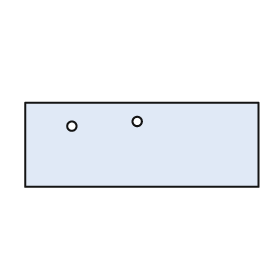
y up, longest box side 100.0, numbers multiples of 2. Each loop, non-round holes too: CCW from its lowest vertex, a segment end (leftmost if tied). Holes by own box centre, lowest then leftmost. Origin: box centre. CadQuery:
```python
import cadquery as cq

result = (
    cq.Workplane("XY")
    .moveTo(-50.0, -18.0)
    .lineTo(50.0, -18.0)
    .lineTo(50.0, 18.0)
    .lineTo(-50.0, 18.0)
    .close()
    .moveTo(-30.0, 8.0)
    .circle(2.0)
    .moveTo(-2.0, 10.0)
    .circle(2.0)
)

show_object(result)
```